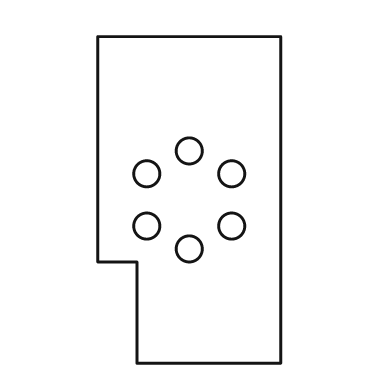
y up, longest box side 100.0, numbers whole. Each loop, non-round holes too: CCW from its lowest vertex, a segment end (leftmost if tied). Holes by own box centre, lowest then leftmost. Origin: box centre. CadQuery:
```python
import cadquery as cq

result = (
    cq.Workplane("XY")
    .moveTo(-16.0, -50.0)
    .lineTo(28.0, -50.0)
    .lineTo(28.0, 50.0)
    .lineTo(-28.0, 50.0)
    .lineTo(-28.0, -19.0)
    .lineTo(-16.0, -19.0)
    .close()
    .moveTo(0.0, -15.0)
    .circle(4.0)
    .moveTo(-13.0, -8.0)
    .circle(4.0)
    .moveTo(13.0, -8.0)
    .circle(4.0)
    .moveTo(-13.0, 8.0)
    .circle(4.0)
    .moveTo(13.0, 8.0)
    .circle(4.0)
    .moveTo(0.0, 15.0)
    .circle(4.0)
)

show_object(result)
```